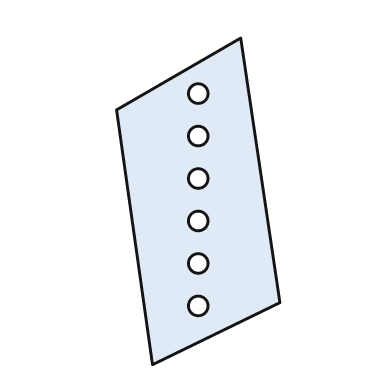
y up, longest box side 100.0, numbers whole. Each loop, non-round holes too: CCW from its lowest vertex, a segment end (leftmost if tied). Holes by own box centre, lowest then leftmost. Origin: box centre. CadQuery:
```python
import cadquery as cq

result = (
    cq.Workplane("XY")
    .moveTo(-14.0, -50.0)
    .lineTo(25.0, -31.0)
    .lineTo(13.0, 50.0)
    .lineTo(-25.0, 28.0)
    .close()
    .moveTo(0.0, -32.0)
    .circle(3.0)
    .moveTo(0.0, -19.0)
    .circle(3.0)
    .moveTo(0.0, -6.0)
    .circle(3.0)
    .moveTo(0.0, 7.0)
    .circle(3.0)
    .moveTo(0.0, 20.0)
    .circle(3.0)
    .moveTo(0.0, 33.0)
    .circle(3.0)
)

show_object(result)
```